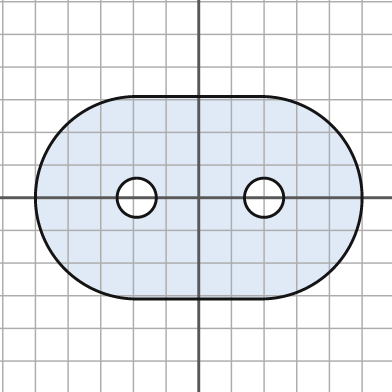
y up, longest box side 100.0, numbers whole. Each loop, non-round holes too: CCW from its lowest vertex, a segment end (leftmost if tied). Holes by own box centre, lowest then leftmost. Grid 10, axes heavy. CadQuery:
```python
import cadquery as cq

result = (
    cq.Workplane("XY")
    .moveTo(-19.0, -31.0)
    .lineTo(19.0, -31.0)
    .threePointArc((50.0, 0.0), (19.0, 31.0))
    .lineTo(-19.0, 31.0)
    .threePointArc((-50.0, 0.0), (-19.0, -31.0))
    .close()
    .moveTo(-19.0, 0.0)
    .circle(6.0)
    .moveTo(20.0, 0.0)
    .circle(6.0)
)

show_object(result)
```